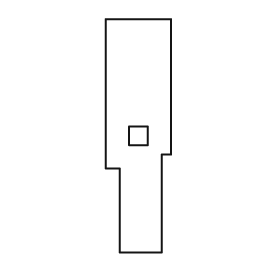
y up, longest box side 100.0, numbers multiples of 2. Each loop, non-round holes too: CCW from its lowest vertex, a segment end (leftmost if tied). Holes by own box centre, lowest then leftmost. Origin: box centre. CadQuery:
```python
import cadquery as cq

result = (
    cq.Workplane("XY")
    .moveTo(-8.0, -50.0)
    .lineTo(10.0, -50.0)
    .lineTo(10.0, -8.0)
    .lineTo(14.0, -8.0)
    .lineTo(14.0, 50.0)
    .lineTo(-14.0, 50.0)
    .lineTo(-14.0, -14.0)
    .lineTo(-8.0, -14.0)
    .close()
    .moveTo(-4.0, -4.0)
    .lineTo(4.0, -4.0)
    .lineTo(4.0, 4.0)
    .lineTo(-4.0, 4.0)
    .close()
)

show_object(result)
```